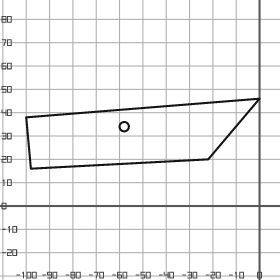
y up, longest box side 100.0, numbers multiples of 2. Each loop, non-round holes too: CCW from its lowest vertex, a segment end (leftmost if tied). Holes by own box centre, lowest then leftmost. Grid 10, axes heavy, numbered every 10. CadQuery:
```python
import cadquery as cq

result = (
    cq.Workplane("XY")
    .moveTo(-98.0, 16.0)
    .lineTo(-22.0, 20.0)
    .lineTo(0.0, 46.0)
    .lineTo(-100.0, 38.0)
    .close()
    .moveTo(-58.0, 34.0)
    .circle(2.0)
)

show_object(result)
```